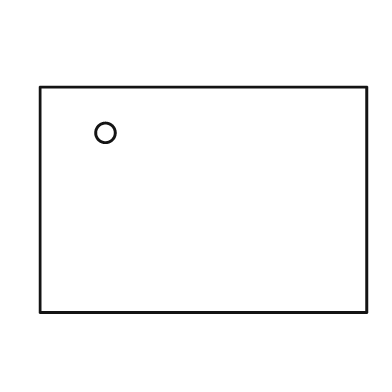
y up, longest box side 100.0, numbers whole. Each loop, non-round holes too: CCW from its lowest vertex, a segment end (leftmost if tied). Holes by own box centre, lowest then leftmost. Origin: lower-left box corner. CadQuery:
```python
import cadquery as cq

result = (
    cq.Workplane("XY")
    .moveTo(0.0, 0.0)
    .lineTo(100.0, 0.0)
    .lineTo(100.0, 69.0)
    .lineTo(0.0, 69.0)
    .close()
    .moveTo(20.0, 55.0)
    .circle(3.0)
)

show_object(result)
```